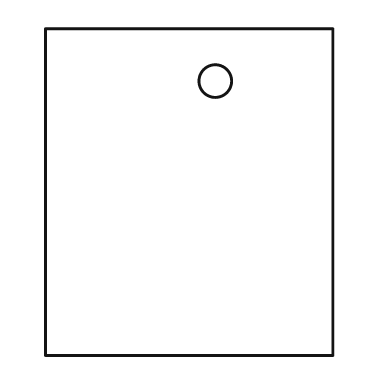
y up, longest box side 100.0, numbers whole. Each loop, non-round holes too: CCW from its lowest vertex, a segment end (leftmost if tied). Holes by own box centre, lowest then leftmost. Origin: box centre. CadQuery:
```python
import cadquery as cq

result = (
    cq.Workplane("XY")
    .moveTo(-44.0, -50.0)
    .lineTo(44.0, -50.0)
    .lineTo(44.0, 50.0)
    .lineTo(-44.0, 50.0)
    .close()
    .moveTo(8.0, 34.0)
    .circle(5.0)
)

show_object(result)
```